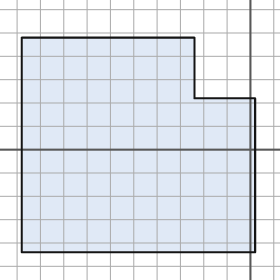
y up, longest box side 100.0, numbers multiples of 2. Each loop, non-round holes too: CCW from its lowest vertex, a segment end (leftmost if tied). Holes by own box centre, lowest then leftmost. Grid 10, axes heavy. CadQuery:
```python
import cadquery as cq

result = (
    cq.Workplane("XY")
    .moveTo(-98.0, -44.0)
    .lineTo(2.0, -44.0)
    .lineTo(2.0, 22.0)
    .lineTo(-24.0, 22.0)
    .lineTo(-24.0, 48.0)
    .lineTo(-98.0, 48.0)
    .close()
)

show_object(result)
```